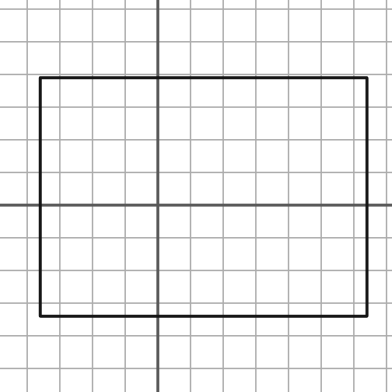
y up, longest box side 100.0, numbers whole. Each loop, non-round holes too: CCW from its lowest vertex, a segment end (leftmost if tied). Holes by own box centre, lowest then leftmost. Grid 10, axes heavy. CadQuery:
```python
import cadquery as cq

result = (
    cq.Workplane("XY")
    .moveTo(-36.0, -34.0)
    .lineTo(64.0, -34.0)
    .lineTo(64.0, 39.0)
    .lineTo(-36.0, 39.0)
    .close()
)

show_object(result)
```